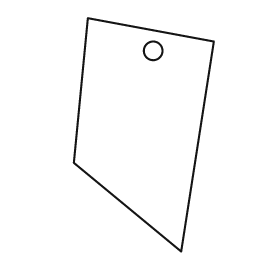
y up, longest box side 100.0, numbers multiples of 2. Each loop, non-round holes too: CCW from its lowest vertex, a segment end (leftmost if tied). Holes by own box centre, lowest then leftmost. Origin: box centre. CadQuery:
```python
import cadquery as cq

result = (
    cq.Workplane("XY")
    .moveTo(16.0, -50.0)
    .lineTo(30.0, 40.0)
    .lineTo(-24.0, 50.0)
    .lineTo(-30.0, -12.0)
    .close()
    .moveTo(4.0, 36.0)
    .circle(4.0)
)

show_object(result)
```